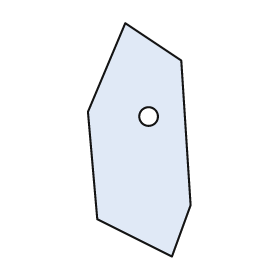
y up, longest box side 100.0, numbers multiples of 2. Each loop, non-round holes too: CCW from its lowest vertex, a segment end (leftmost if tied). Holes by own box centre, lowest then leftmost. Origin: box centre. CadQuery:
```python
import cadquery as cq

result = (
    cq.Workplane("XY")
    .moveTo(14.0, -50.0)
    .lineTo(22.0, -28.0)
    .lineTo(18.0, 34.0)
    .lineTo(-6.0, 50.0)
    .lineTo(-22.0, 12.0)
    .lineTo(-18.0, -34.0)
    .close()
    .moveTo(4.0, 10.0)
    .circle(4.0)
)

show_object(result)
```